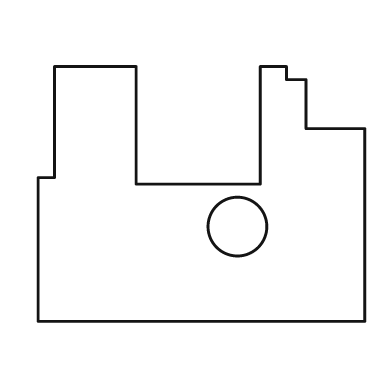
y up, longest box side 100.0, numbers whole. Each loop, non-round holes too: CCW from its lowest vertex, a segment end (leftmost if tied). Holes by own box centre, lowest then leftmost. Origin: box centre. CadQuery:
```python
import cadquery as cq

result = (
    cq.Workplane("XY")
    .moveTo(-50.0, -39.0)
    .lineTo(50.0, -39.0)
    .lineTo(50.0, 20.0)
    .lineTo(32.0, 20.0)
    .lineTo(32.0, 35.0)
    .lineTo(26.0, 35.0)
    .lineTo(26.0, 39.0)
    .lineTo(18.0, 39.0)
    .lineTo(18.0, 3.0)
    .lineTo(-20.0, 3.0)
    .lineTo(-20.0, 39.0)
    .lineTo(-45.0, 39.0)
    .lineTo(-45.0, 5.0)
    .lineTo(-50.0, 5.0)
    .close()
    .moveTo(11.0, -10.0)
    .circle(9.0)
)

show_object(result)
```